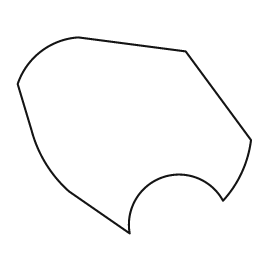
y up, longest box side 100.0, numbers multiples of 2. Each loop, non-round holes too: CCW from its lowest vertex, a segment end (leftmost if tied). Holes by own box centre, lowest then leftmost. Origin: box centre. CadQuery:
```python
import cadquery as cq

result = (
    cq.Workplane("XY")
    .moveTo(-2.0, -42.0)
    .threePointArc((12.0, -18.0), (38.0, -28.0))
    .threePointArc((46.0, -16.0), (50.0, -2.0))
    .lineTo(22.0, 36.0)
    .lineTo(-24.0, 42.0)
    .threePointArc((-40.0, 36.0), (-50.0, 22.0))
    .lineTo(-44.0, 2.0)
    .threePointArc((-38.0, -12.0), (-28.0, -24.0))
    .close()
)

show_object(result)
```